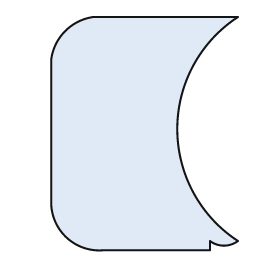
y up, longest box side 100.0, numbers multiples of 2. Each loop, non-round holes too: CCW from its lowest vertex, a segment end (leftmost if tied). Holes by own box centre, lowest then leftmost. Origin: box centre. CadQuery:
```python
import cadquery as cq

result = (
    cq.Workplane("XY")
    .moveTo(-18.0, -50.0)
    .lineTo(28.0, -50.0)
    .lineTo(28.0, -46.0)
    .threePointArc((34.0, -48.0), (40.0, -46.0))
    .threePointArc((14.0, 2.0), (40.0, 50.0))
    .lineTo(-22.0, 50.0)
    .threePointArc((-34.0, 44.0), (-40.0, 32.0))
    .lineTo(-40.0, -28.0)
    .threePointArc((-34.0, -44.0), (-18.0, -50.0))
    .close()
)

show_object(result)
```